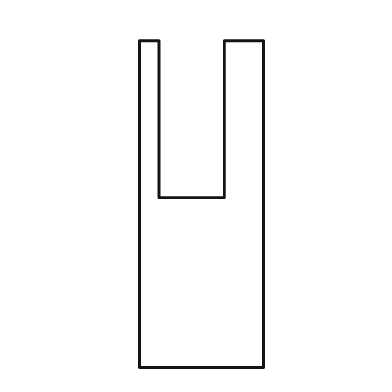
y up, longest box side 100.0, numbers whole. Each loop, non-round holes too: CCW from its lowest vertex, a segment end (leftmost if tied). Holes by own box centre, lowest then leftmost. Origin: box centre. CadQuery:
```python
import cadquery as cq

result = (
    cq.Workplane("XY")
    .moveTo(-19.0, -50.0)
    .lineTo(19.0, -50.0)
    .lineTo(19.0, 50.0)
    .lineTo(7.0, 50.0)
    .lineTo(7.0, 2.0)
    .lineTo(-13.0, 2.0)
    .lineTo(-13.0, 50.0)
    .lineTo(-19.0, 50.0)
    .close()
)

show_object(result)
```